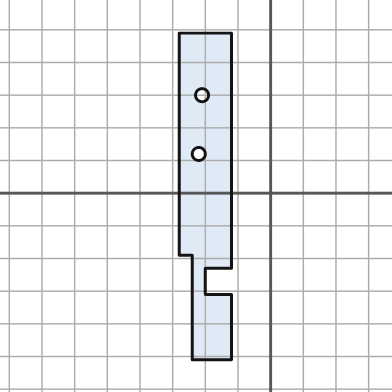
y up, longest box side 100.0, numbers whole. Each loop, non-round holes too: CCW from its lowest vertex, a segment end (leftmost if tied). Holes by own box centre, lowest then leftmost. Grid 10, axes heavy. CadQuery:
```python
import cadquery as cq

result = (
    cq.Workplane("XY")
    .moveTo(-24.0, -51.0)
    .lineTo(-12.0, -51.0)
    .lineTo(-12.0, -31.0)
    .lineTo(-20.0, -31.0)
    .lineTo(-20.0, -23.0)
    .lineTo(-12.0, -23.0)
    .lineTo(-12.0, 49.0)
    .lineTo(-28.0, 49.0)
    .lineTo(-28.0, -19.0)
    .lineTo(-24.0, -19.0)
    .close()
    .moveTo(-22.0, 12.0)
    .circle(2.0)
    .moveTo(-21.0, 30.0)
    .circle(2.0)
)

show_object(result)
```